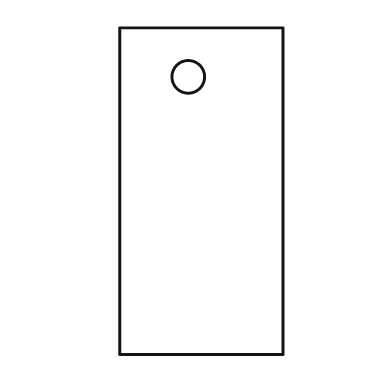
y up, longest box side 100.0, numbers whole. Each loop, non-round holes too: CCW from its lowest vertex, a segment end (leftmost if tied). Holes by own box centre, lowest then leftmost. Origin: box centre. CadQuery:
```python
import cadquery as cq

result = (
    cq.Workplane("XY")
    .moveTo(-25.0, -50.0)
    .lineTo(25.0, -50.0)
    .lineTo(25.0, 50.0)
    .lineTo(-25.0, 50.0)
    .close()
    .moveTo(-4.0, 35.0)
    .circle(5.0)
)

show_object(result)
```